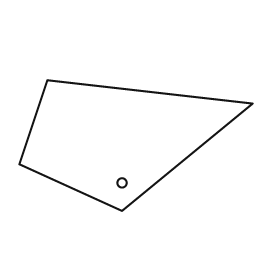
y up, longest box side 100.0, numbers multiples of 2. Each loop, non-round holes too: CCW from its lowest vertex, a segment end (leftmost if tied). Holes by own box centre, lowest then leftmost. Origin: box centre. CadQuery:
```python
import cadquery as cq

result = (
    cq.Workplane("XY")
    .moveTo(-6.0, -28.0)
    .lineTo(50.0, 18.0)
    .lineTo(-38.0, 28.0)
    .lineTo(-50.0, -8.0)
    .close()
    .moveTo(-6.0, -16.0)
    .circle(2.0)
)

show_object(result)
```